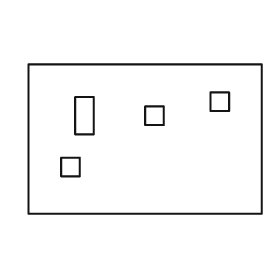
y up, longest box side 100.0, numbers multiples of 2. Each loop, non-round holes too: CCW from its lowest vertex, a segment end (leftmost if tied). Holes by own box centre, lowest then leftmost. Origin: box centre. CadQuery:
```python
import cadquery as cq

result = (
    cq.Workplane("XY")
    .moveTo(-50.0, -32.0)
    .lineTo(50.0, -32.0)
    .lineTo(50.0, 32.0)
    .lineTo(-50.0, 32.0)
    .close()
    .moveTo(-36.0, -16.0)
    .lineTo(-28.0, -16.0)
    .lineTo(-28.0, -8.0)
    .lineTo(-36.0, -8.0)
    .close()
    .moveTo(-30.0, 2.0)
    .lineTo(-22.0, 2.0)
    .lineTo(-22.0, 18.0)
    .lineTo(-30.0, 18.0)
    .close()
    .moveTo(0.0, 6.0)
    .lineTo(8.0, 6.0)
    .lineTo(8.0, 14.0)
    .lineTo(0.0, 14.0)
    .close()
    .moveTo(28.0, 12.0)
    .lineTo(36.0, 12.0)
    .lineTo(36.0, 20.0)
    .lineTo(28.0, 20.0)
    .close()
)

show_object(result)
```